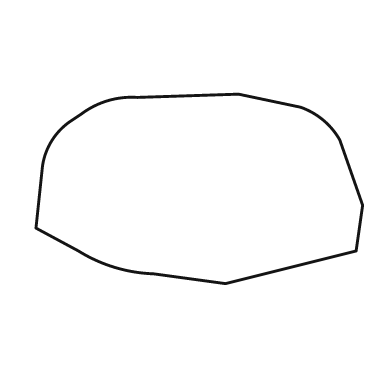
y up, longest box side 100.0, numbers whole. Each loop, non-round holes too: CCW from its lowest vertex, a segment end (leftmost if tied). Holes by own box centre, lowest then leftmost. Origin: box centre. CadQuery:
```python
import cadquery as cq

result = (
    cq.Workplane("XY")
    .moveTo(8.0, -29.0)
    .lineTo(48.0, -19.0)
    .lineTo(50.0, -5.0)
    .lineTo(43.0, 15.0)
    .threePointArc((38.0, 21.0), (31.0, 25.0))
    .lineTo(12.0, 29.0)
    .lineTo(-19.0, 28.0)
    .threePointArc((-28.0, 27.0), (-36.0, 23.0))
    .lineTo(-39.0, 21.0)
    .threePointArc((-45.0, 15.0), (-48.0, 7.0))
    .lineTo(-50.0, -12.0)
    .lineTo(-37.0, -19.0)
    .threePointArc((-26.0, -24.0), (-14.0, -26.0))
    .close()
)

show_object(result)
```